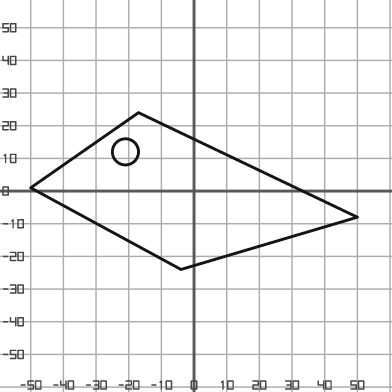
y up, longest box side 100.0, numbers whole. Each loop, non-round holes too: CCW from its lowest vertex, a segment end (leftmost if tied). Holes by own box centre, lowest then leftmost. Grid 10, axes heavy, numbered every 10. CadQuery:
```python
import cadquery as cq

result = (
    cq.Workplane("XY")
    .moveTo(-4.0, -24.0)
    .lineTo(50.0, -8.0)
    .lineTo(-17.0, 24.0)
    .lineTo(-50.0, 1.0)
    .close()
    .moveTo(-21.0, 12.0)
    .circle(4.0)
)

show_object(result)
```